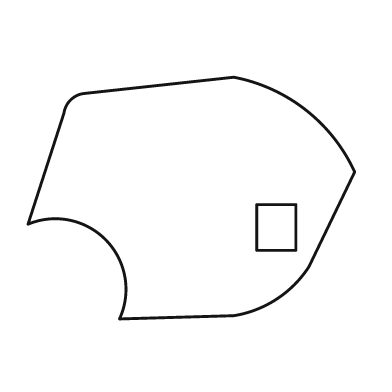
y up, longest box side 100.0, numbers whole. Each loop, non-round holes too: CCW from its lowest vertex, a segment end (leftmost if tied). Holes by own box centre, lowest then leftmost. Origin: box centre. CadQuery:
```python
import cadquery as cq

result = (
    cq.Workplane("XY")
    .moveTo(-22.0, -37.0)
    .lineTo(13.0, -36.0)
    .threePointArc((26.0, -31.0), (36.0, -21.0))
    .lineTo(50.0, 8.0)
    .threePointArc((35.0, 27.0), (13.0, 37.0))
    .lineTo(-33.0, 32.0)
    .threePointArc((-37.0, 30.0), (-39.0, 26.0))
    .lineTo(-50.0, -8.0)
    .threePointArc((-26.0, -13.0), (-22.0, -37.0))
    .close()
    .moveTo(20.0, -16.0)
    .lineTo(32.0, -16.0)
    .lineTo(32.0, -2.0)
    .lineTo(20.0, -2.0)
    .close()
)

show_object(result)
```